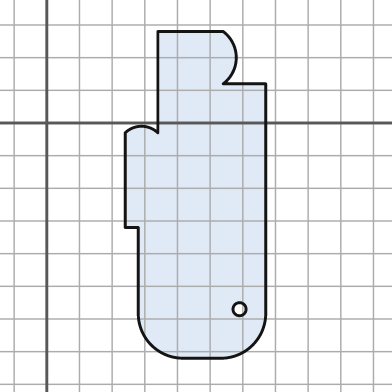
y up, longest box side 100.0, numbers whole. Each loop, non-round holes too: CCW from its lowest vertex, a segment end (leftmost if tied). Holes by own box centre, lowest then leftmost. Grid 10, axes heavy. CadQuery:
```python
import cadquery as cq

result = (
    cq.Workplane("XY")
    .moveTo(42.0, -72.0)
    .lineTo(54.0, -72.0)
    .threePointArc((63.0, -68.0), (67.0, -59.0))
    .lineTo(67.0, 12.0)
    .lineTo(54.0, 12.0)
    .threePointArc((58.0, 20.0), (54.0, 28.0))
    .lineTo(34.0, 28.0)
    .lineTo(34.0, -3.0)
    .threePointArc((29.0, -1.0), (24.0, -3.0))
    .lineTo(24.0, -32.0)
    .lineTo(28.0, -32.0)
    .lineTo(28.0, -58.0)
    .threePointArc((32.0, -68.0), (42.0, -72.0))
    .close()
    .moveTo(59.0, -57.0)
    .circle(2.0)
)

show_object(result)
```